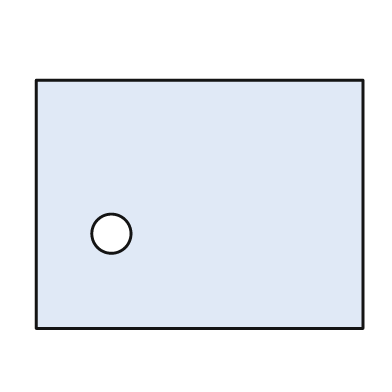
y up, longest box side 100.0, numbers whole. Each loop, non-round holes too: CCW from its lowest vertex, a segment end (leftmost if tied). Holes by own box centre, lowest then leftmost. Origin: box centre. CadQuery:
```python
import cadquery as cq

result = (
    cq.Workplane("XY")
    .moveTo(-50.0, -38.0)
    .lineTo(50.0, -38.0)
    .lineTo(50.0, 38.0)
    .lineTo(-50.0, 38.0)
    .close()
    .moveTo(-27.0, -9.0)
    .circle(6.0)
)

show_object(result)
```